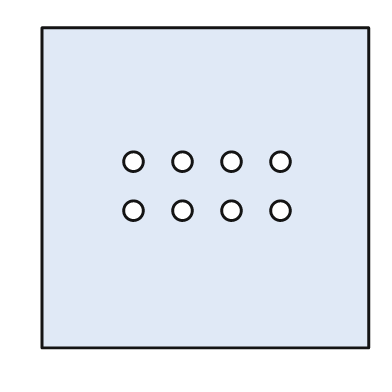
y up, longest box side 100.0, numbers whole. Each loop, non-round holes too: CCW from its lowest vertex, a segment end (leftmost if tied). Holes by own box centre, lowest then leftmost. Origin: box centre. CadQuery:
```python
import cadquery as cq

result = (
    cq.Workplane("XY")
    .moveTo(-50.0, -49.0)
    .lineTo(50.0, -49.0)
    .lineTo(50.0, 49.0)
    .lineTo(-50.0, 49.0)
    .close()
    .moveTo(-22.0, -7.0)
    .circle(3.0)
    .moveTo(-7.0, -7.0)
    .circle(3.0)
    .moveTo(8.0, -7.0)
    .circle(3.0)
    .moveTo(23.0, -7.0)
    .circle(3.0)
    .moveTo(-22.0, 8.0)
    .circle(3.0)
    .moveTo(-7.0, 8.0)
    .circle(3.0)
    .moveTo(8.0, 8.0)
    .circle(3.0)
    .moveTo(23.0, 8.0)
    .circle(3.0)
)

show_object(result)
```